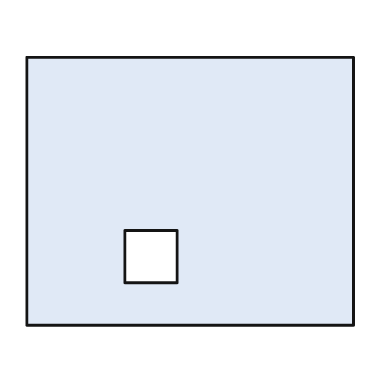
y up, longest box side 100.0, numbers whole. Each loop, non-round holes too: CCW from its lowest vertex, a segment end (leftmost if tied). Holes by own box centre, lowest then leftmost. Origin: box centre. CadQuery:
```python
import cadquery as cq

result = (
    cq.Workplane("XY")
    .moveTo(-50.0, -41.0)
    .lineTo(50.0, -41.0)
    .lineTo(50.0, 41.0)
    .lineTo(-50.0, 41.0)
    .close()
    .moveTo(-20.0, -28.0)
    .lineTo(-4.0, -28.0)
    .lineTo(-4.0, -12.0)
    .lineTo(-20.0, -12.0)
    .close()
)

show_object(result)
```